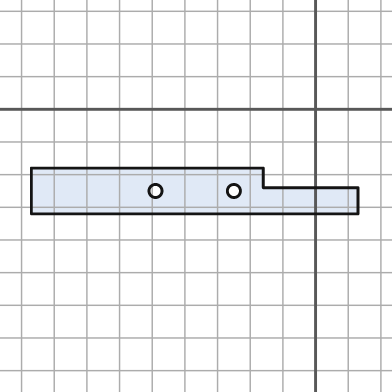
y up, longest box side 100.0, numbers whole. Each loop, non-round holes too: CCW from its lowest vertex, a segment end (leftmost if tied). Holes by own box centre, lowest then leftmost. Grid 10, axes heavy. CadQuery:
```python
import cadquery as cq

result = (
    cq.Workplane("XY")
    .moveTo(-87.0, -32.0)
    .lineTo(13.0, -32.0)
    .lineTo(13.0, -24.0)
    .lineTo(-16.0, -24.0)
    .lineTo(-16.0, -18.0)
    .lineTo(-87.0, -18.0)
    .close()
    .moveTo(-49.0, -25.0)
    .circle(2.0)
    .moveTo(-25.0, -25.0)
    .circle(2.0)
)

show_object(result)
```